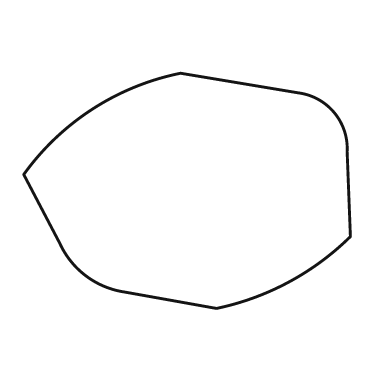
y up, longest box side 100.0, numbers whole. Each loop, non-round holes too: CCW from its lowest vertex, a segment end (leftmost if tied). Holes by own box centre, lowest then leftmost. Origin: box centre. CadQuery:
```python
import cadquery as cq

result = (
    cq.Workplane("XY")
    .moveTo(9.0, -36.0)
    .threePointArc((31.0, -28.0), (50.0, -14.0))
    .lineTo(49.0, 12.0)
    .threePointArc((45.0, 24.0), (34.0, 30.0))
    .lineTo(-2.0, 36.0)
    .threePointArc((-29.0, 25.0), (-50.0, 5.0))
    .lineTo(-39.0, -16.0)
    .threePointArc((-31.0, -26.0), (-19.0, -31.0))
    .close()
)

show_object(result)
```